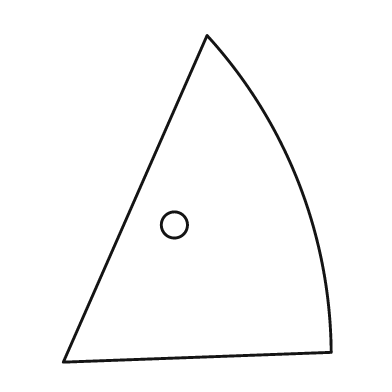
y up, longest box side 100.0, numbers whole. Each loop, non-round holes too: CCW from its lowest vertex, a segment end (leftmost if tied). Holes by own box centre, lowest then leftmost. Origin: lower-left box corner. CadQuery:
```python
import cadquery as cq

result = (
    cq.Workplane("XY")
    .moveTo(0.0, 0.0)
    .lineTo(82.0, 3.0)
    .threePointArc((72.0, 55.0), (44.0, 100.0))
    .close()
    .moveTo(34.0, 42.0)
    .circle(4.0)
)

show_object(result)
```